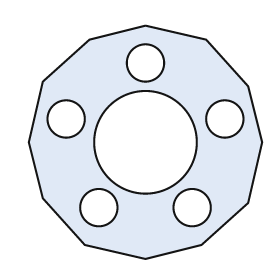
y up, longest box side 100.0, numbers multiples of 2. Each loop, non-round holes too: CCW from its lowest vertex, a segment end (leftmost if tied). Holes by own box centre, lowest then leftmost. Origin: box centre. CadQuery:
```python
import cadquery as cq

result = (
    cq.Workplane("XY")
    .moveTo(0.0, -50.0)
    .lineTo(24.0, -44.0)
    .lineTo(44.0, -26.0)
    .lineTo(50.0, 0.0)
    .lineTo(44.0, 24.0)
    .lineTo(26.0, 44.0)
    .lineTo(0.0, 50.0)
    .lineTo(-24.0, 44.0)
    .lineTo(-44.0, 26.0)
    .lineTo(-50.0, 0.0)
    .lineTo(-44.0, -24.0)
    .lineTo(-26.0, -44.0)
    .close()
    .moveTo(-20.0, -28.0)
    .circle(8.0)
    .moveTo(20.0, -28.0)
    .circle(8.0)
    .moveTo(0.0, 0.0)
    .circle(22.0)
    .moveTo(-34.0, 10.0)
    .circle(8.0)
    .moveTo(34.0, 10.0)
    .circle(8.0)
    .moveTo(0.0, 34.0)
    .circle(8.0)
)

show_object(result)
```